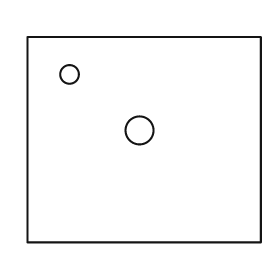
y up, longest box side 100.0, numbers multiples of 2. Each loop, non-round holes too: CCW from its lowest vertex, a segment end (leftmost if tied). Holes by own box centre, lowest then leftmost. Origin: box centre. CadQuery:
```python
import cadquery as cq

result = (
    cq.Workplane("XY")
    .moveTo(-50.0, -44.0)
    .lineTo(50.0, -44.0)
    .lineTo(50.0, 44.0)
    .lineTo(-50.0, 44.0)
    .close()
    .moveTo(-2.0, 4.0)
    .circle(6.0)
    .moveTo(-32.0, 28.0)
    .circle(4.0)
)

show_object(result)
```